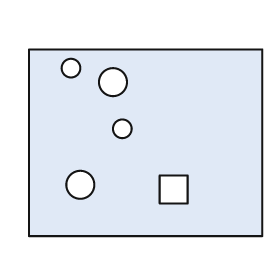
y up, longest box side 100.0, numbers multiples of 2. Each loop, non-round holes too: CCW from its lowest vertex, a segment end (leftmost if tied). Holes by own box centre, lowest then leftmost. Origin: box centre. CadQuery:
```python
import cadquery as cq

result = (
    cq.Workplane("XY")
    .moveTo(-50.0, -40.0)
    .lineTo(50.0, -40.0)
    .lineTo(50.0, 40.0)
    .lineTo(-50.0, 40.0)
    .close()
    .moveTo(6.0, -26.0)
    .lineTo(18.0, -26.0)
    .lineTo(18.0, -14.0)
    .lineTo(6.0, -14.0)
    .close()
    .moveTo(-28.0, -18.0)
    .circle(6.0)
    .moveTo(-10.0, 6.0)
    .circle(4.0)
    .moveTo(-14.0, 26.0)
    .circle(6.0)
    .moveTo(-32.0, 32.0)
    .circle(4.0)
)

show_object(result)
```